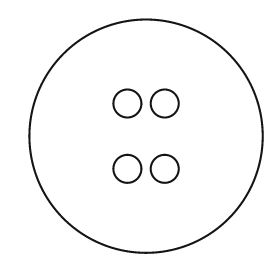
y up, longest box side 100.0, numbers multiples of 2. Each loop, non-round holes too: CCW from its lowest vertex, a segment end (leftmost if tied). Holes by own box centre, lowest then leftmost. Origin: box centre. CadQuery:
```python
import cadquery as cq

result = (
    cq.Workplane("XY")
    .moveTo(0.0, 0.0)
    .circle(50.0)
    .moveTo(-8.0, -14.0)
    .circle(6.0)
    .moveTo(8.0, -14.0)
    .circle(6.0)
    .moveTo(-8.0, 14.0)
    .circle(6.0)
    .moveTo(8.0, 14.0)
    .circle(6.0)
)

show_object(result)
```